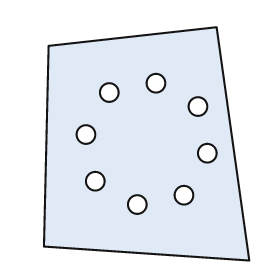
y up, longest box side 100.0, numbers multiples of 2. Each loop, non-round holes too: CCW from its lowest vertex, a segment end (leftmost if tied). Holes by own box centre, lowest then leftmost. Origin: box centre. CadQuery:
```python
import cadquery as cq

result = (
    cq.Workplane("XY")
    .moveTo(44.0, -50.0)
    .lineTo(30.0, 50.0)
    .lineTo(-42.0, 42.0)
    .lineTo(-44.0, -44.0)
    .close()
    .moveTo(-4.0, -26.0)
    .circle(4.0)
    .moveTo(16.0, -22.0)
    .circle(4.0)
    .moveTo(-22.0, -16.0)
    .circle(4.0)
    .moveTo(26.0, -4.0)
    .circle(4.0)
    .moveTo(-26.0, 4.0)
    .circle(4.0)
    .moveTo(22.0, 16.0)
    .circle(4.0)
    .moveTo(-16.0, 22.0)
    .circle(4.0)
    .moveTo(4.0, 26.0)
    .circle(4.0)
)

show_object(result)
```